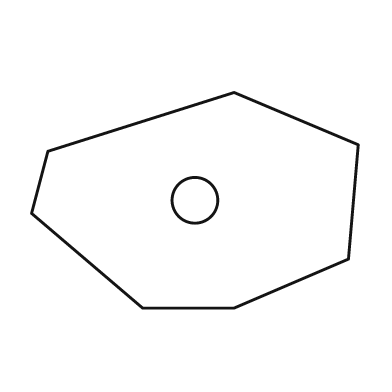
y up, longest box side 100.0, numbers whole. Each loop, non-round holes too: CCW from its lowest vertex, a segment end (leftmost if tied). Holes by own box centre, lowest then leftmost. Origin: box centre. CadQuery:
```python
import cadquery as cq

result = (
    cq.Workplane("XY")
    .moveTo(-16.0, -33.0)
    .lineTo(12.0, -33.0)
    .lineTo(47.0, -18.0)
    .lineTo(50.0, 17.0)
    .lineTo(12.0, 33.0)
    .lineTo(-45.0, 15.0)
    .lineTo(-50.0, -4.0)
    .close()
    .moveTo(0.0, 0.0)
    .circle(7.0)
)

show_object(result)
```